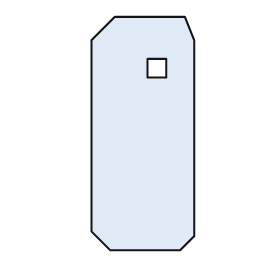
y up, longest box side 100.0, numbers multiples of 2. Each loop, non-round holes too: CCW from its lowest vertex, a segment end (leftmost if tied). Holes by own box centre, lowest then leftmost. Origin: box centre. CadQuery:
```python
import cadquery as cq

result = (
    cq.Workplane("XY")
    .moveTo(-14.0, -50.0)
    .lineTo(16.0, -50.0)
    .lineTo(22.0, -44.0)
    .lineTo(22.0, 40.0)
    .lineTo(18.0, 50.0)
    .lineTo(-12.0, 50.0)
    .lineTo(-22.0, 40.0)
    .lineTo(-22.0, -42.0)
    .close()
    .moveTo(2.0, 24.0)
    .lineTo(10.0, 24.0)
    .lineTo(10.0, 32.0)
    .lineTo(2.0, 32.0)
    .close()
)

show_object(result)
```